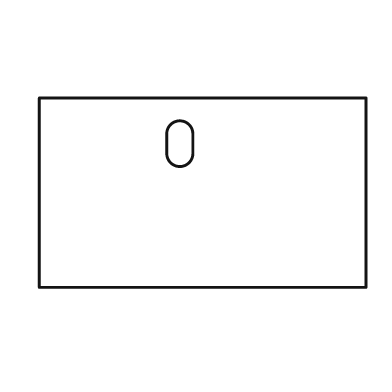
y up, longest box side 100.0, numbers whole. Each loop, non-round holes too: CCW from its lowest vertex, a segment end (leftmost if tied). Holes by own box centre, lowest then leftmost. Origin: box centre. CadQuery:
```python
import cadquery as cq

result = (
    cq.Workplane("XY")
    .moveTo(-50.0, -29.0)
    .lineTo(50.0, -29.0)
    .lineTo(50.0, 29.0)
    .lineTo(-50.0, 29.0)
    .close()
    .moveTo(-11.0, 12.0)
    .threePointArc((-7.0, 8.0), (-3.0, 12.0))
    .lineTo(-3.0, 18.0)
    .threePointArc((-7.0, 22.0), (-11.0, 18.0))
    .close()
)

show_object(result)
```